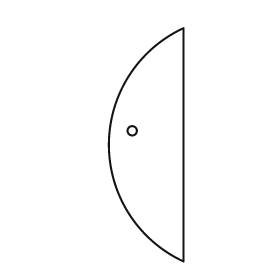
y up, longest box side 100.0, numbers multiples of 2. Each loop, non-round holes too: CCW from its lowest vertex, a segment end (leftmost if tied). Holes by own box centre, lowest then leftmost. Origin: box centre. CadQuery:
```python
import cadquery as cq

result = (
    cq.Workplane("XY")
    .moveTo(16.0, -50.0)
    .lineTo(16.0, 50.0)
    .threePointArc((-16.0, 0.0), (16.0, -50.0))
    .close()
    .moveTo(-6.0, 6.0)
    .circle(2.0)
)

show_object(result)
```